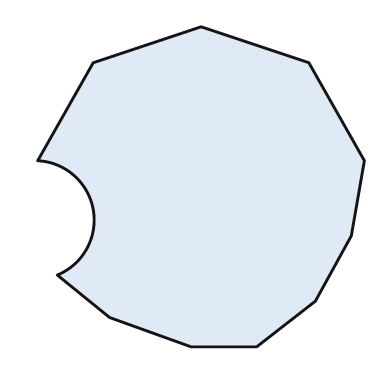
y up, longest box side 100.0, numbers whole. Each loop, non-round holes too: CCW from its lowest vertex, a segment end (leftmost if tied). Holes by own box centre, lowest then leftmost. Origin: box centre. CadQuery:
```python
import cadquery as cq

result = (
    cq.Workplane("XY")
    .moveTo(-3.0, -49.0)
    .lineTo(17.0, -49.0)
    .lineTo(35.0, -35.0)
    .lineTo(46.0, -15.0)
    .lineTo(50.0, 8.0)
    .lineTo(33.0, 38.0)
    .lineTo(0.0, 49.0)
    .lineTo(-33.0, 38.0)
    .lineTo(-50.0, 8.0)
    .threePointArc((-33.0, -7.0), (-44.0, -27.0))
    .lineTo(-28.0, -40.0)
    .close()
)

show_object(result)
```